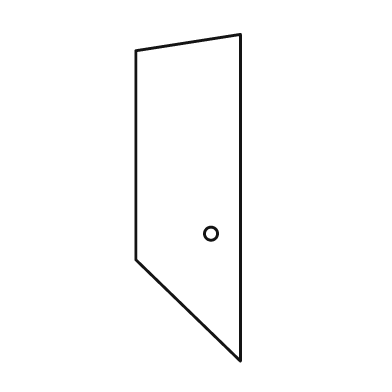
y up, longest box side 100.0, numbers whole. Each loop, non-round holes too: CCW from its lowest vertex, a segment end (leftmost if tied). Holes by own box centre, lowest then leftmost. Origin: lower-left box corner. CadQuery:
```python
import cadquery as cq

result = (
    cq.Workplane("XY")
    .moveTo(32.0, 0.0)
    .lineTo(32.0, 100.0)
    .lineTo(0.0, 95.0)
    .lineTo(0.0, 31.0)
    .close()
    .moveTo(23.0, 39.0)
    .circle(2.0)
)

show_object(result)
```